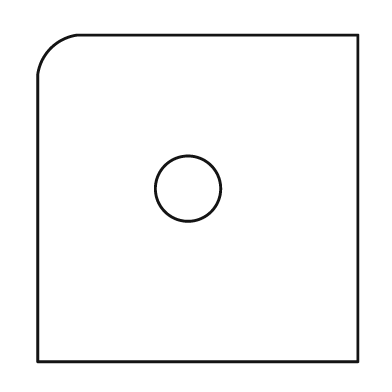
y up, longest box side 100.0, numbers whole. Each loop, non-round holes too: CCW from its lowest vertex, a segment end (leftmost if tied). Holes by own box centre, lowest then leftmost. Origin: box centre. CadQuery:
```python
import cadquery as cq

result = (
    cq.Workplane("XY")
    .moveTo(-49.0, -50.0)
    .lineTo(49.0, -50.0)
    .lineTo(49.0, 50.0)
    .lineTo(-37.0, 50.0)
    .threePointArc((-45.0, 46.0), (-49.0, 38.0))
    .close()
    .moveTo(-3.0, 3.0)
    .circle(10.0)
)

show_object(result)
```